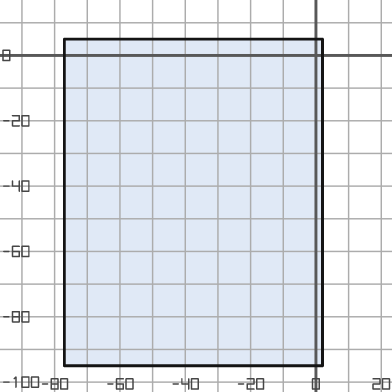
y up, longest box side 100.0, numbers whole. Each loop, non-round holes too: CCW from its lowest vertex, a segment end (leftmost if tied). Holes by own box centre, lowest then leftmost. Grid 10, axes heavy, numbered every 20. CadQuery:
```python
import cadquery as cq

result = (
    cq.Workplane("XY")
    .moveTo(-77.0, -95.0)
    .lineTo(2.0, -95.0)
    .lineTo(2.0, 5.0)
    .lineTo(-77.0, 5.0)
    .close()
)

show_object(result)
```